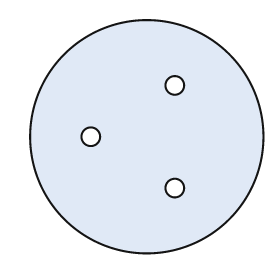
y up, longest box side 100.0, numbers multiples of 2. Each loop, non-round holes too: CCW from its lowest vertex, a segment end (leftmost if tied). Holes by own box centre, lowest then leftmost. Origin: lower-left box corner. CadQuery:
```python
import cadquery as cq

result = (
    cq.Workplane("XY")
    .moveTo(50.0, 50.0)
    .circle(50.0)
    .moveTo(62.0, 28.0)
    .circle(4.0)
    .moveTo(26.0, 50.0)
    .circle(4.0)
    .moveTo(62.0, 72.0)
    .circle(4.0)
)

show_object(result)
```